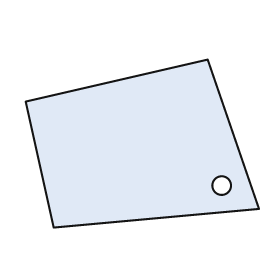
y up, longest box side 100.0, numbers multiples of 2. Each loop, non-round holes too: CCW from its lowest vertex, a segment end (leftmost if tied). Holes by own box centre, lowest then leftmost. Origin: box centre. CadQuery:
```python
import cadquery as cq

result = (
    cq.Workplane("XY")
    .moveTo(-38.0, -36.0)
    .lineTo(50.0, -28.0)
    .lineTo(28.0, 36.0)
    .lineTo(-50.0, 18.0)
    .close()
    .moveTo(34.0, -18.0)
    .circle(4.0)
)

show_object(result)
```